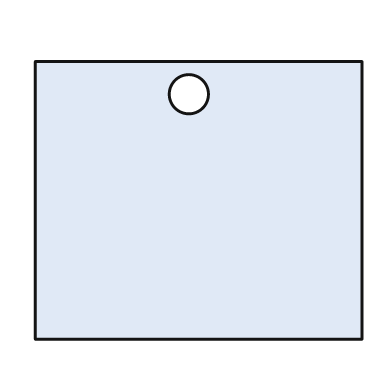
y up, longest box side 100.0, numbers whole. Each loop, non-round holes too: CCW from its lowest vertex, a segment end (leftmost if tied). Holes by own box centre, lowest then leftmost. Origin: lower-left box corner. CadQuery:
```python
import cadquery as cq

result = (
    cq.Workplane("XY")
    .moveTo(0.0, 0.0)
    .lineTo(100.0, 0.0)
    .lineTo(100.0, 85.0)
    .lineTo(0.0, 85.0)
    .close()
    .moveTo(47.0, 75.0)
    .circle(6.0)
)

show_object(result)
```